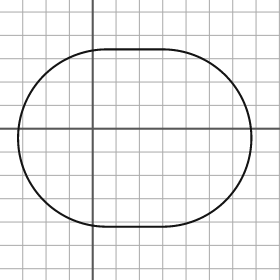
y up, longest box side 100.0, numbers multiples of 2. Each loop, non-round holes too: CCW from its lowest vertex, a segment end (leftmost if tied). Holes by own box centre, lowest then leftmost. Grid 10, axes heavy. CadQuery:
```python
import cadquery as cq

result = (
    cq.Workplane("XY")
    .moveTo(6.0, -42.0)
    .lineTo(30.0, -42.0)
    .threePointArc((68.0, -4.0), (30.0, 34.0))
    .lineTo(6.0, 34.0)
    .threePointArc((-32.0, -4.0), (6.0, -42.0))
    .close()
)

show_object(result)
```